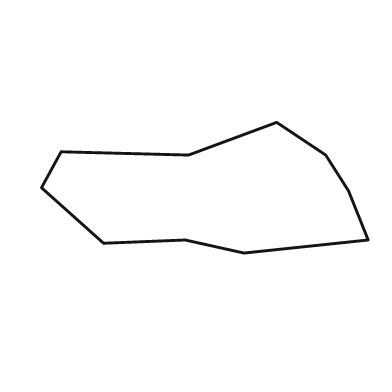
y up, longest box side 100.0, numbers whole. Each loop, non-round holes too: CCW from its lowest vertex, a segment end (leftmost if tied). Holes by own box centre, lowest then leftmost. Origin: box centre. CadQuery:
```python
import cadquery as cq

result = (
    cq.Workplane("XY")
    .moveTo(12.0, -20.0)
    .lineTo(50.0, -16.0)
    .lineTo(44.0, -1.0)
    .lineTo(37.0, 10.0)
    .lineTo(22.0, 20.0)
    .lineTo(-5.0, 10.0)
    .lineTo(-44.0, 11.0)
    .lineTo(-50.0, 0.0)
    .lineTo(-31.0, -17.0)
    .lineTo(-6.0, -16.0)
    .close()
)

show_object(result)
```